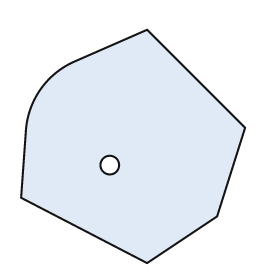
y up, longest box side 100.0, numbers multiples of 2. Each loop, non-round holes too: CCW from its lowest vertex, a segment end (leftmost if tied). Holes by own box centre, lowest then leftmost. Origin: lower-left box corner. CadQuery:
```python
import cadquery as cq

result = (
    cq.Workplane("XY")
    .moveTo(54.0, 0.0)
    .lineTo(84.0, 20.0)
    .lineTo(96.0, 58.0)
    .lineTo(54.0, 100.0)
    .lineTo(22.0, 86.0)
    .threePointArc((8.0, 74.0), (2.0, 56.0))
    .lineTo(0.0, 28.0)
    .close()
    .moveTo(38.0, 42.0)
    .circle(4.0)
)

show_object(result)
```